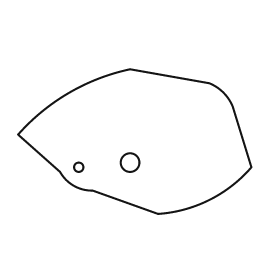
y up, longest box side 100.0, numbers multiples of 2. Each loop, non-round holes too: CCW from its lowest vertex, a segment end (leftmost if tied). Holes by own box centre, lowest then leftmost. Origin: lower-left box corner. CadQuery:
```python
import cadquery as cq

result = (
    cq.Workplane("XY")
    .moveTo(60.0, 0.0)
    .threePointArc((82.0, 6.0), (100.0, 20.0))
    .lineTo(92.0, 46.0)
    .threePointArc((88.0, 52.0), (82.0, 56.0))
    .lineTo(48.0, 62.0)
    .threePointArc((22.0, 52.0), (0.0, 34.0))
    .lineTo(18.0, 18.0)
    .threePointArc((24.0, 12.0), (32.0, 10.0))
    .close()
    .moveTo(26.0, 20.0)
    .circle(2.0)
    .moveTo(48.0, 22.0)
    .circle(4.0)
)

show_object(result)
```